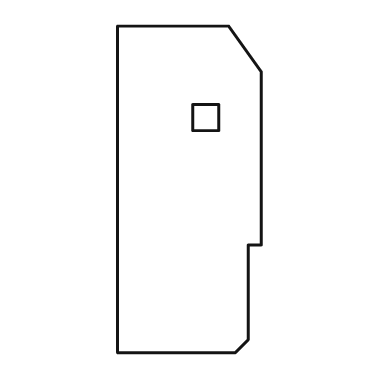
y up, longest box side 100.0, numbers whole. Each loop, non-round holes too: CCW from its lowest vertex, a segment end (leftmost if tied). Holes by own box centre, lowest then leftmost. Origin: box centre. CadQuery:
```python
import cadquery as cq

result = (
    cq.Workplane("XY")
    .moveTo(-22.0, -50.0)
    .lineTo(14.0, -50.0)
    .lineTo(18.0, -46.0)
    .lineTo(18.0, -17.0)
    .lineTo(22.0, -17.0)
    .lineTo(22.0, 36.0)
    .lineTo(12.0, 50.0)
    .lineTo(-22.0, 50.0)
    .close()
    .moveTo(1.0, 18.0)
    .lineTo(9.0, 18.0)
    .lineTo(9.0, 26.0)
    .lineTo(1.0, 26.0)
    .close()
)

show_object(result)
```